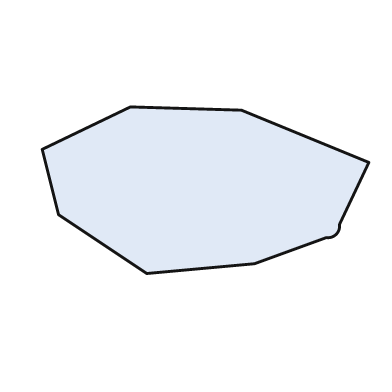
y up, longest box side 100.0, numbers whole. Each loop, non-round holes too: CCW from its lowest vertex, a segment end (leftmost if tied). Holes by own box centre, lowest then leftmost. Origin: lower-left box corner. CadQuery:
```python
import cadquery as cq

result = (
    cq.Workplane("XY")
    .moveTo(32.0, 0.0)
    .lineTo(65.0, 3.0)
    .lineTo(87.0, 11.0)
    .threePointArc((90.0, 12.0), (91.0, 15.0))
    .lineTo(100.0, 34.0)
    .lineTo(61.0, 50.0)
    .lineTo(27.0, 51.0)
    .lineTo(0.0, 38.0)
    .lineTo(5.0, 18.0)
    .close()
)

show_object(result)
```